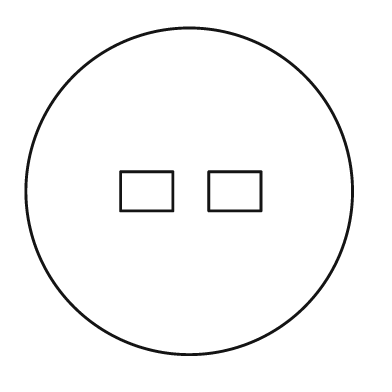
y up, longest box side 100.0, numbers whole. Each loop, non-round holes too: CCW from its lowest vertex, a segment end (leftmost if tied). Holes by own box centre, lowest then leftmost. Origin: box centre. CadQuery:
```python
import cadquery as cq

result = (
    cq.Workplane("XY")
    .moveTo(0.0, 0.0)
    .circle(50.0)
    .moveTo(-21.0, -6.0)
    .lineTo(-5.0, -6.0)
    .lineTo(-5.0, 6.0)
    .lineTo(-21.0, 6.0)
    .close()
    .moveTo(6.0, -6.0)
    .lineTo(22.0, -6.0)
    .lineTo(22.0, 6.0)
    .lineTo(6.0, 6.0)
    .close()
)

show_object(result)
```